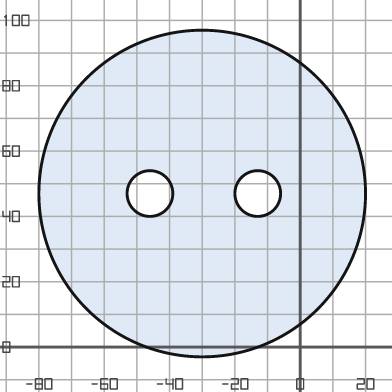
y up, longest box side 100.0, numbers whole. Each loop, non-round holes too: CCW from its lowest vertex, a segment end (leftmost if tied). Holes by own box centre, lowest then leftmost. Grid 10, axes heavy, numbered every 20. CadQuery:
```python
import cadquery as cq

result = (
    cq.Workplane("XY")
    .moveTo(-30.0, 47.0)
    .circle(50.0)
    .moveTo(-46.0, 47.0)
    .circle(7.0)
    .moveTo(-13.0, 47.0)
    .circle(7.0)
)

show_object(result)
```